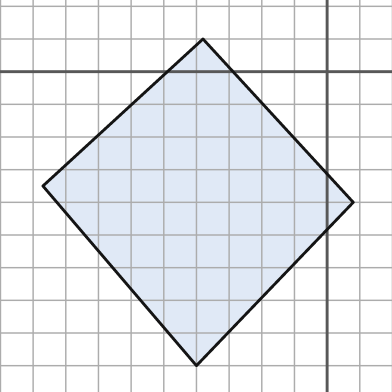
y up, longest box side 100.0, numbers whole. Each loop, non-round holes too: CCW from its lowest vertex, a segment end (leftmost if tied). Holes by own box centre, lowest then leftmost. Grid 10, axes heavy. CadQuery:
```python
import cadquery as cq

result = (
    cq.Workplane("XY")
    .moveTo(-40.0, -90.0)
    .lineTo(8.0, -40.0)
    .lineTo(-38.0, 10.0)
    .lineTo(-87.0, -35.0)
    .close()
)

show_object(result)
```